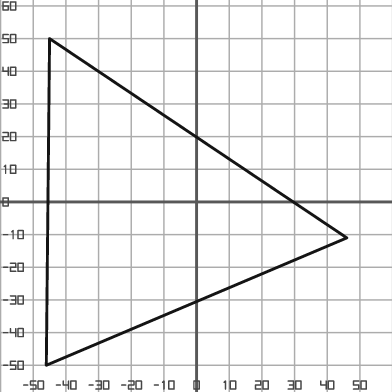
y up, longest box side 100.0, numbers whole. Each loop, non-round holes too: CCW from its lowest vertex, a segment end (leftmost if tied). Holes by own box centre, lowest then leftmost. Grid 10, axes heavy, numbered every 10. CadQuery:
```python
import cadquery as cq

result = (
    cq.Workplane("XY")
    .moveTo(-46.0, -50.0)
    .lineTo(46.0, -11.0)
    .lineTo(-45.0, 50.0)
    .close()
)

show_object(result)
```